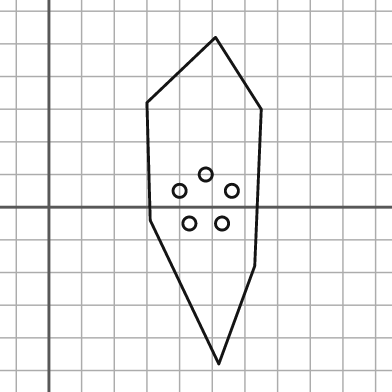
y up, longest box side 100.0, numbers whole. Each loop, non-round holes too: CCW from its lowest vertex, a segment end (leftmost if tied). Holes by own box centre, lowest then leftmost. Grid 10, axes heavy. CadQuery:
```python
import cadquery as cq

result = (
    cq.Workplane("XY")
    .moveTo(52.0, -48.0)
    .lineTo(63.0, -18.0)
    .lineTo(65.0, 30.0)
    .lineTo(51.0, 52.0)
    .lineTo(30.0, 32.0)
    .lineTo(31.0, -4.0)
    .close()
    .moveTo(43.0, -5.0)
    .circle(2.0)
    .moveTo(53.0, -5.0)
    .circle(2.0)
    .moveTo(40.0, 5.0)
    .circle(2.0)
    .moveTo(56.0, 5.0)
    .circle(2.0)
    .moveTo(48.0, 10.0)
    .circle(2.0)
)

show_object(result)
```